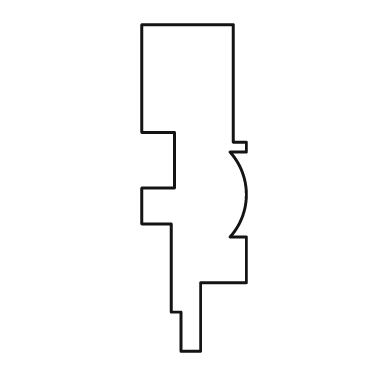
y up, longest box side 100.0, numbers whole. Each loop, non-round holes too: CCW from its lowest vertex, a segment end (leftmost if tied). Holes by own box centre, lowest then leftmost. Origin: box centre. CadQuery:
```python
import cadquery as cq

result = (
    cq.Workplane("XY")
    .moveTo(-4.0, -50.0)
    .lineTo(2.0, -50.0)
    .lineTo(2.0, -29.0)
    .lineTo(16.0, -29.0)
    .lineTo(16.0, -15.0)
    .lineTo(11.0, -15.0)
    .threePointArc((16.0, -2.0), (11.0, 11.0))
    .lineTo(16.0, 11.0)
    .lineTo(16.0, 14.0)
    .lineTo(12.0, 14.0)
    .lineTo(12.0, 50.0)
    .lineTo(-16.0, 50.0)
    .lineTo(-16.0, 17.0)
    .lineTo(-6.0, 17.0)
    .lineTo(-6.0, 0.0)
    .lineTo(-16.0, 0.0)
    .lineTo(-16.0, -11.0)
    .lineTo(-7.0, -11.0)
    .lineTo(-7.0, -38.0)
    .lineTo(-4.0, -38.0)
    .close()
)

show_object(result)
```